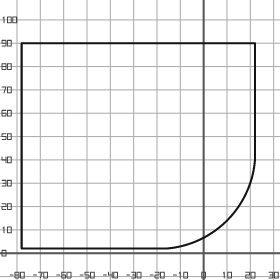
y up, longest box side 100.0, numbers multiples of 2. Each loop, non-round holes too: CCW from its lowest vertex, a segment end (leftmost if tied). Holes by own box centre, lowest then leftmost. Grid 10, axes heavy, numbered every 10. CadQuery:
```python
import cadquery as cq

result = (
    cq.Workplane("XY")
    .moveTo(-78.0, 2.0)
    .lineTo(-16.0, 2.0)
    .threePointArc((10.0, 14.0), (22.0, 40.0))
    .lineTo(22.0, 90.0)
    .lineTo(-78.0, 90.0)
    .close()
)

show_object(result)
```